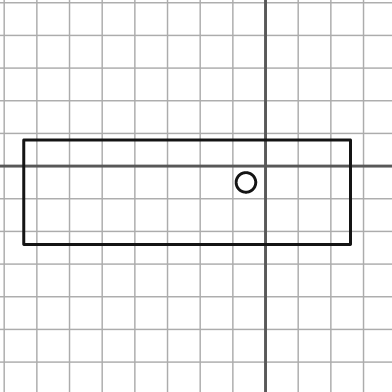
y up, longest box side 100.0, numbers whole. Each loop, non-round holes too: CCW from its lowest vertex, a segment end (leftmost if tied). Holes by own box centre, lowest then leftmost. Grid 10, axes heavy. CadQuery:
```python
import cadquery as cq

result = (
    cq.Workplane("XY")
    .moveTo(-74.0, -24.0)
    .lineTo(26.0, -24.0)
    .lineTo(26.0, 8.0)
    .lineTo(-74.0, 8.0)
    .close()
    .moveTo(-6.0, -5.0)
    .circle(3.0)
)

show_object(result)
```